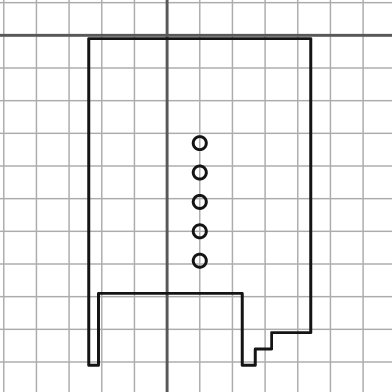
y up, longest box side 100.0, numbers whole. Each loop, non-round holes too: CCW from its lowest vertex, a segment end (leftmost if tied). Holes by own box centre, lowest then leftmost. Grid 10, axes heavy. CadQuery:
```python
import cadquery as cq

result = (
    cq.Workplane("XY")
    .moveTo(-24.0, -101.0)
    .lineTo(-21.0, -101.0)
    .lineTo(-21.0, -79.0)
    .lineTo(23.0, -79.0)
    .lineTo(23.0, -101.0)
    .lineTo(27.0, -101.0)
    .lineTo(27.0, -96.0)
    .lineTo(32.0, -96.0)
    .lineTo(32.0, -91.0)
    .lineTo(44.0, -91.0)
    .lineTo(44.0, -1.0)
    .lineTo(-24.0, -1.0)
    .close()
    .moveTo(10.0, -69.0)
    .circle(2.0)
    .moveTo(10.0, -60.0)
    .circle(2.0)
    .moveTo(10.0, -51.0)
    .circle(2.0)
    .moveTo(10.0, -42.0)
    .circle(2.0)
    .moveTo(10.0, -33.0)
    .circle(2.0)
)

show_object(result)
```